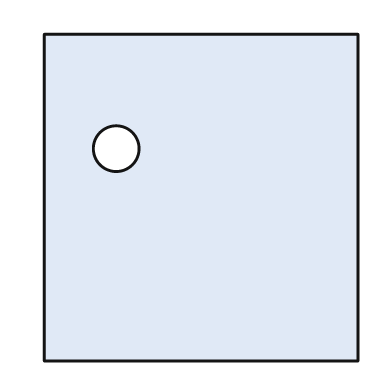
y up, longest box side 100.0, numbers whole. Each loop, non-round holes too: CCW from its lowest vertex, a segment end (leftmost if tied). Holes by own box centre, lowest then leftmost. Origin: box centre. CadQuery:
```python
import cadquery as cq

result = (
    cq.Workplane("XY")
    .moveTo(-48.0, -50.0)
    .lineTo(48.0, -50.0)
    .lineTo(48.0, 50.0)
    .lineTo(-48.0, 50.0)
    .close()
    .moveTo(-26.0, 15.0)
    .circle(7.0)
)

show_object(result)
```